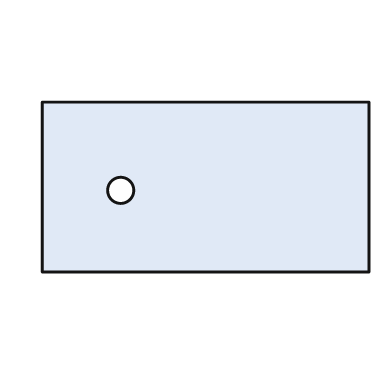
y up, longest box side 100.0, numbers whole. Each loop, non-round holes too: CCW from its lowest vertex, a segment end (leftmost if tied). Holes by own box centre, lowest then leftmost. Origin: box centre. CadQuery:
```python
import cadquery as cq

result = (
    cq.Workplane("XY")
    .moveTo(-50.0, -26.0)
    .lineTo(50.0, -26.0)
    .lineTo(50.0, 26.0)
    .lineTo(-50.0, 26.0)
    .close()
    .moveTo(-26.0, -1.0)
    .circle(4.0)
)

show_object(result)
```